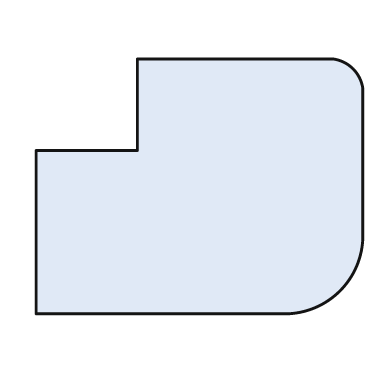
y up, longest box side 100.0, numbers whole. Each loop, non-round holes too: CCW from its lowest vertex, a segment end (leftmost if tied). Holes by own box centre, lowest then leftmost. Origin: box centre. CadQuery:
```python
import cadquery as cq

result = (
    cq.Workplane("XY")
    .moveTo(-50.0, -39.0)
    .lineTo(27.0, -39.0)
    .threePointArc((43.0, -32.0), (50.0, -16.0))
    .lineTo(50.0, 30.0)
    .threePointArc((47.0, 36.0), (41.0, 39.0))
    .lineTo(-19.0, 39.0)
    .lineTo(-19.0, 11.0)
    .lineTo(-50.0, 11.0)
    .close()
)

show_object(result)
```